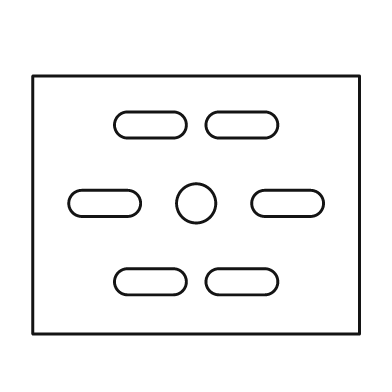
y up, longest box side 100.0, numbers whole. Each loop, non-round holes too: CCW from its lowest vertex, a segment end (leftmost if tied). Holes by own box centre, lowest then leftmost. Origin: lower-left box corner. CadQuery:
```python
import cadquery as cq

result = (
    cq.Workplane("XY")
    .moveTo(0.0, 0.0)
    .lineTo(100.0, 0.0)
    .lineTo(100.0, 79.0)
    .lineTo(0.0, 79.0)
    .close()
    .moveTo(29.0, 12.0)
    .lineTo(43.0, 12.0)
    .threePointArc((47.0, 16.0), (43.0, 20.0))
    .lineTo(29.0, 20.0)
    .threePointArc((25.0, 16.0), (29.0, 12.0))
    .close()
    .moveTo(57.0, 12.0)
    .lineTo(71.0, 12.0)
    .threePointArc((75.0, 16.0), (71.0, 20.0))
    .lineTo(57.0, 20.0)
    .threePointArc((53.0, 16.0), (57.0, 12.0))
    .close()
    .moveTo(15.0, 36.0)
    .lineTo(29.0, 36.0)
    .threePointArc((33.0, 40.0), (29.0, 44.0))
    .lineTo(15.0, 44.0)
    .threePointArc((11.0, 40.0), (15.0, 36.0))
    .close()
    .moveTo(50.0, 40.0)
    .circle(6.0)
    .moveTo(71.0, 36.0)
    .lineTo(85.0, 36.0)
    .threePointArc((89.0, 40.0), (85.0, 44.0))
    .lineTo(71.0, 44.0)
    .threePointArc((67.0, 40.0), (71.0, 36.0))
    .close()
    .moveTo(29.0, 60.0)
    .lineTo(43.0, 60.0)
    .threePointArc((47.0, 64.0), (43.0, 68.0))
    .lineTo(29.0, 68.0)
    .threePointArc((25.0, 64.0), (29.0, 60.0))
    .close()
    .moveTo(57.0, 60.0)
    .lineTo(71.0, 60.0)
    .threePointArc((75.0, 64.0), (71.0, 68.0))
    .lineTo(57.0, 68.0)
    .threePointArc((53.0, 64.0), (57.0, 60.0))
    .close()
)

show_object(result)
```